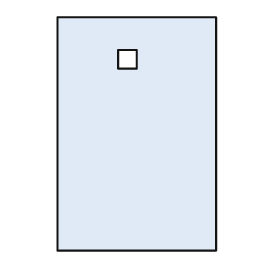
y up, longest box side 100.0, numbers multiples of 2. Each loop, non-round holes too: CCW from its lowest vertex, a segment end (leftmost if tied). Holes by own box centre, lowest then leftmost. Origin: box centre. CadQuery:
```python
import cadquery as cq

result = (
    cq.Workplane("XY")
    .moveTo(-34.0, -50.0)
    .lineTo(34.0, -50.0)
    .lineTo(34.0, 50.0)
    .lineTo(-34.0, 50.0)
    .close()
    .moveTo(-8.0, 28.0)
    .lineTo(0.0, 28.0)
    .lineTo(0.0, 36.0)
    .lineTo(-8.0, 36.0)
    .close()
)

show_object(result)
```